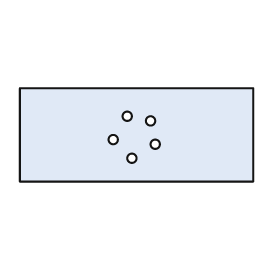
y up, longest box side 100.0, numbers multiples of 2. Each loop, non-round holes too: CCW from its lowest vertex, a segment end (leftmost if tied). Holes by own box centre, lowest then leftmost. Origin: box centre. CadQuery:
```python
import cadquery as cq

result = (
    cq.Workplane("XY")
    .moveTo(-50.0, -20.0)
    .lineTo(50.0, -20.0)
    .lineTo(50.0, 20.0)
    .lineTo(-50.0, 20.0)
    .close()
    .moveTo(-2.0, -10.0)
    .circle(2.0)
    .moveTo(8.0, -4.0)
    .circle(2.0)
    .moveTo(-10.0, -2.0)
    .circle(2.0)
    .moveTo(6.0, 6.0)
    .circle(2.0)
    .moveTo(-4.0, 8.0)
    .circle(2.0)
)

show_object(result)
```